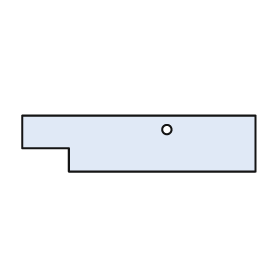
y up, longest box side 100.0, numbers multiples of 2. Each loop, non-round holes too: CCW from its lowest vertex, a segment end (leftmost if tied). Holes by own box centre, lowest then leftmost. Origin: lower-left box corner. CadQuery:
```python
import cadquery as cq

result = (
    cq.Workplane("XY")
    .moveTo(20.0, 0.0)
    .lineTo(100.0, 0.0)
    .lineTo(100.0, 24.0)
    .lineTo(0.0, 24.0)
    .lineTo(0.0, 10.0)
    .lineTo(20.0, 10.0)
    .close()
    .moveTo(62.0, 18.0)
    .circle(2.0)
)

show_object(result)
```